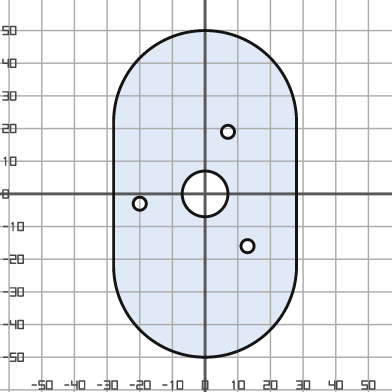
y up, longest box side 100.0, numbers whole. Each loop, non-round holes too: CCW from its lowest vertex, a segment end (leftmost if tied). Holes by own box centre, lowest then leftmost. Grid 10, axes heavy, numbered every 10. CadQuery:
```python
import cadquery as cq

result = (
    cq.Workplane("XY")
    .moveTo(-28.0, -22.0)
    .threePointArc((0.0, -50.0), (28.0, -22.0))
    .lineTo(28.0, 22.0)
    .threePointArc((0.0, 50.0), (-28.0, 22.0))
    .close()
    .moveTo(13.0, -16.0)
    .circle(2.0)
    .moveTo(-20.0, -3.0)
    .circle(2.0)
    .moveTo(0.0, 0.0)
    .circle(7.0)
    .moveTo(7.0, 19.0)
    .circle(2.0)
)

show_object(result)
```